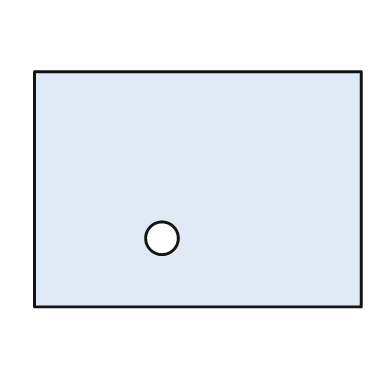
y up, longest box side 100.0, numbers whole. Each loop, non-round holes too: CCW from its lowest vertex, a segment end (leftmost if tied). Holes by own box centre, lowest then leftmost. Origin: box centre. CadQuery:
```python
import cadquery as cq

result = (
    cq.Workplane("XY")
    .moveTo(-50.0, -36.0)
    .lineTo(50.0, -36.0)
    .lineTo(50.0, 36.0)
    .lineTo(-50.0, 36.0)
    .close()
    .moveTo(-11.0, -15.0)
    .circle(5.0)
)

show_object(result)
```